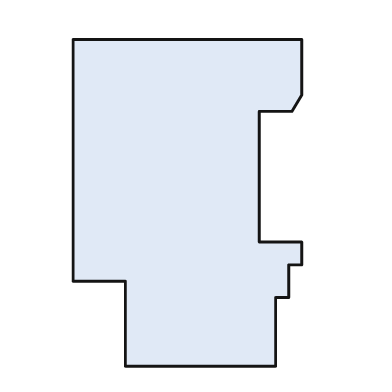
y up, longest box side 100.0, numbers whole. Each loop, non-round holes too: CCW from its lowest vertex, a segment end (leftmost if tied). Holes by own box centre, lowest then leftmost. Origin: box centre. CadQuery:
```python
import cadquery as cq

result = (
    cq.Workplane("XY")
    .moveTo(-19.0, -50.0)
    .lineTo(27.0, -50.0)
    .lineTo(27.0, -29.0)
    .lineTo(31.0, -29.0)
    .lineTo(31.0, -19.0)
    .lineTo(35.0, -19.0)
    .lineTo(35.0, -12.0)
    .lineTo(22.0, -12.0)
    .lineTo(22.0, 28.0)
    .lineTo(32.0, 28.0)
    .lineTo(35.0, 33.0)
    .lineTo(35.0, 50.0)
    .lineTo(-35.0, 50.0)
    .lineTo(-35.0, -24.0)
    .lineTo(-19.0, -24.0)
    .close()
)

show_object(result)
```